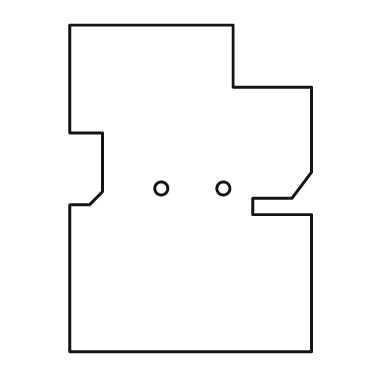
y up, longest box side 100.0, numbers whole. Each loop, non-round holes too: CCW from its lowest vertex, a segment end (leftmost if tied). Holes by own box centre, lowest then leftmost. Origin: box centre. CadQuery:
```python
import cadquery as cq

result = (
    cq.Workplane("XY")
    .moveTo(-37.0, -50.0)
    .lineTo(37.0, -50.0)
    .lineTo(37.0, -8.0)
    .lineTo(19.0, -8.0)
    .lineTo(19.0, -3.0)
    .lineTo(31.0, -3.0)
    .lineTo(37.0, 5.0)
    .lineTo(37.0, 31.0)
    .lineTo(13.0, 31.0)
    .lineTo(13.0, 50.0)
    .lineTo(-37.0, 50.0)
    .lineTo(-37.0, 17.0)
    .lineTo(-27.0, 17.0)
    .lineTo(-27.0, -1.0)
    .lineTo(-31.0, -5.0)
    .lineTo(-37.0, -5.0)
    .close()
    .moveTo(-9.0, 0.0)
    .circle(2.0)
    .moveTo(10.0, 0.0)
    .circle(2.0)
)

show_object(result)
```